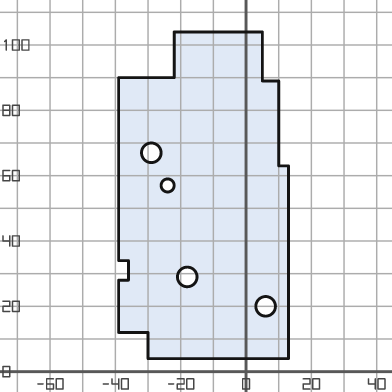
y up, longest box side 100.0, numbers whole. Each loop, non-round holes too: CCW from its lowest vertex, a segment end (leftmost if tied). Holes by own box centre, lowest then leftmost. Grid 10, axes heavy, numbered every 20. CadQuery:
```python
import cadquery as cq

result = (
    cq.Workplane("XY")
    .moveTo(-30.0, 4.0)
    .lineTo(13.0, 4.0)
    .lineTo(13.0, 63.0)
    .lineTo(10.0, 63.0)
    .lineTo(10.0, 89.0)
    .lineTo(5.0, 89.0)
    .lineTo(5.0, 104.0)
    .lineTo(-22.0, 104.0)
    .lineTo(-22.0, 90.0)
    .lineTo(-39.0, 90.0)
    .lineTo(-39.0, 34.0)
    .lineTo(-36.0, 34.0)
    .lineTo(-36.0, 28.0)
    .lineTo(-39.0, 28.0)
    .lineTo(-39.0, 12.0)
    .lineTo(-30.0, 12.0)
    .close()
    .moveTo(6.0, 20.0)
    .circle(3.0)
    .moveTo(-18.0, 29.0)
    .circle(3.0)
    .moveTo(-24.0, 57.0)
    .circle(2.0)
    .moveTo(-29.0, 67.0)
    .circle(3.0)
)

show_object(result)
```